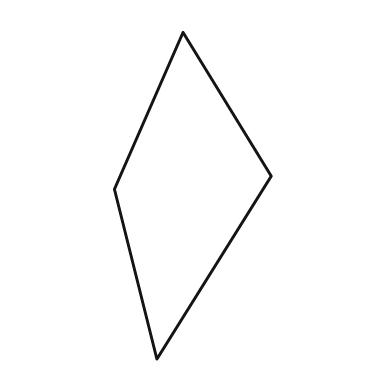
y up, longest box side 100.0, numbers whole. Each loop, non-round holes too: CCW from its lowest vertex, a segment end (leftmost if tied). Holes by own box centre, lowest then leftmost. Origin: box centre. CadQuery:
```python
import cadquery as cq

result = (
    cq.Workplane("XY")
    .moveTo(-11.0, -50.0)
    .lineTo(24.0, 6.0)
    .lineTo(-3.0, 50.0)
    .lineTo(-24.0, 2.0)
    .close()
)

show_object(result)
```